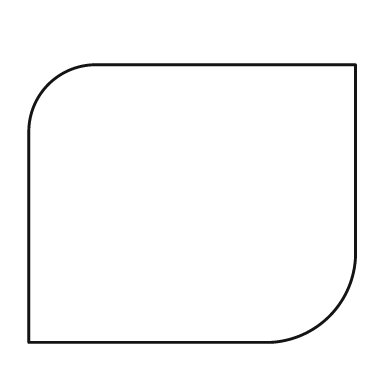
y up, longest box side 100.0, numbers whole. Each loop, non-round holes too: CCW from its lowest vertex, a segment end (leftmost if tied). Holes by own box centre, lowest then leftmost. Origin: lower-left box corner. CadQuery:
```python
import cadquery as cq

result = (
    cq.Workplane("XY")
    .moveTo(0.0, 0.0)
    .lineTo(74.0, 0.0)
    .threePointArc((92.0, 8.0), (100.0, 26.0))
    .lineTo(100.0, 85.0)
    .lineTo(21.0, 85.0)
    .threePointArc((6.0, 79.0), (0.0, 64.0))
    .close()
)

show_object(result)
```